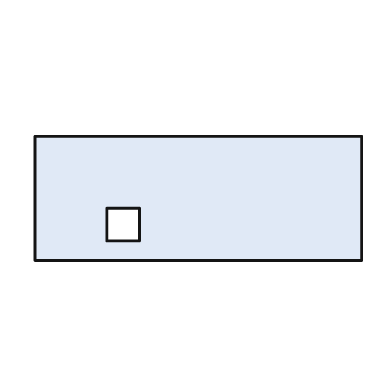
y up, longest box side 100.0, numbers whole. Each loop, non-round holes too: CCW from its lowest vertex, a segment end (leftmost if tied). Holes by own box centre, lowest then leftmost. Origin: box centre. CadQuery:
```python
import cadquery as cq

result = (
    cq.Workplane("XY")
    .moveTo(-50.0, -19.0)
    .lineTo(50.0, -19.0)
    .lineTo(50.0, 19.0)
    .lineTo(-50.0, 19.0)
    .close()
    .moveTo(-28.0, -13.0)
    .lineTo(-18.0, -13.0)
    .lineTo(-18.0, -3.0)
    .lineTo(-28.0, -3.0)
    .close()
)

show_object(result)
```